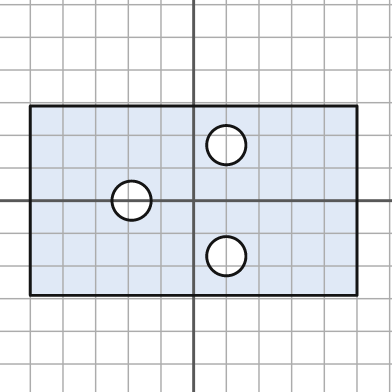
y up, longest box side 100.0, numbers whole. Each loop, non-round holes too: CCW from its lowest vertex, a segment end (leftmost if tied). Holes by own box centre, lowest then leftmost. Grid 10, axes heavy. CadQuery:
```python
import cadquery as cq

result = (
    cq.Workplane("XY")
    .moveTo(-50.0, -29.0)
    .lineTo(50.0, -29.0)
    .lineTo(50.0, 29.0)
    .lineTo(-50.0, 29.0)
    .close()
    .moveTo(10.0, -17.0)
    .circle(6.0)
    .moveTo(-19.0, 0.0)
    .circle(6.0)
    .moveTo(10.0, 17.0)
    .circle(6.0)
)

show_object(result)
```